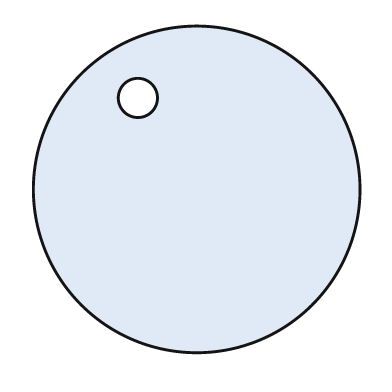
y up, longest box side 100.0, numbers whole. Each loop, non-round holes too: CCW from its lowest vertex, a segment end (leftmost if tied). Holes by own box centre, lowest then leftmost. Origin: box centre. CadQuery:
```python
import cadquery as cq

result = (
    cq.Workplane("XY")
    .moveTo(0.0, 0.0)
    .circle(50.0)
    .moveTo(-18.0, 28.0)
    .circle(6.0)
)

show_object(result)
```